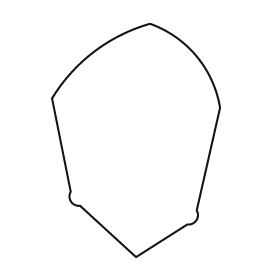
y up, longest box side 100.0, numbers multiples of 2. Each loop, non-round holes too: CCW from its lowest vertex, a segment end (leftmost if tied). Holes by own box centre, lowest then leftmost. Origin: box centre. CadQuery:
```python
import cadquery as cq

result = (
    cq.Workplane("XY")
    .moveTo(0.0, -50.0)
    .lineTo(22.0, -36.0)
    .threePointArc((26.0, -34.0), (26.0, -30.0))
    .lineTo(36.0, 14.0)
    .threePointArc((26.0, 36.0), (6.0, 50.0))
    .threePointArc((-18.0, 38.0), (-36.0, 18.0))
    .lineTo(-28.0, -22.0)
    .threePointArc((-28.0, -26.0), (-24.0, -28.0))
    .close()
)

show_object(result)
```